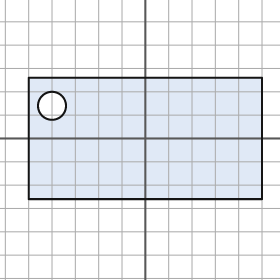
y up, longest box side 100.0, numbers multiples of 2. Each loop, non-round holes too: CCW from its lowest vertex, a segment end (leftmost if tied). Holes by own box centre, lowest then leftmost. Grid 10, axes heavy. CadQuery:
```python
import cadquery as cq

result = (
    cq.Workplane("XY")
    .moveTo(-50.0, -26.0)
    .lineTo(50.0, -26.0)
    .lineTo(50.0, 26.0)
    .lineTo(-50.0, 26.0)
    .close()
    .moveTo(-40.0, 14.0)
    .circle(6.0)
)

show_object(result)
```